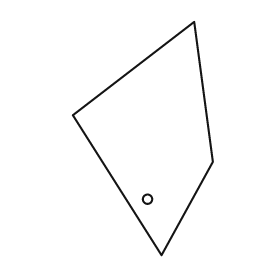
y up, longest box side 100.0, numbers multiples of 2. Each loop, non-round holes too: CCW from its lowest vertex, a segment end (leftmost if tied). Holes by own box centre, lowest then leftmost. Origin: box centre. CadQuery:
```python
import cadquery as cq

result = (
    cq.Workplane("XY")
    .moveTo(8.0, -50.0)
    .lineTo(30.0, -10.0)
    .lineTo(22.0, 50.0)
    .lineTo(-30.0, 10.0)
    .close()
    .moveTo(2.0, -26.0)
    .circle(2.0)
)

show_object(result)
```